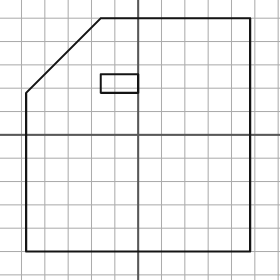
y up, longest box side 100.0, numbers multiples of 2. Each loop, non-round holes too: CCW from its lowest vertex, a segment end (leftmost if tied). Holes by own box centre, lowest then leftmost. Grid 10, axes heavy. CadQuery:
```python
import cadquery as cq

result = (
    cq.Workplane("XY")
    .moveTo(-48.0, -50.0)
    .lineTo(48.0, -50.0)
    .lineTo(48.0, 50.0)
    .lineTo(-16.0, 50.0)
    .lineTo(-48.0, 18.0)
    .close()
    .moveTo(-16.0, 18.0)
    .lineTo(0.0, 18.0)
    .lineTo(0.0, 26.0)
    .lineTo(-16.0, 26.0)
    .close()
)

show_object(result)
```